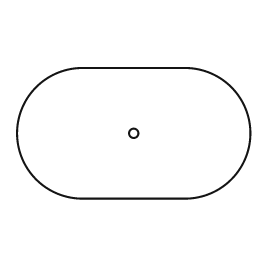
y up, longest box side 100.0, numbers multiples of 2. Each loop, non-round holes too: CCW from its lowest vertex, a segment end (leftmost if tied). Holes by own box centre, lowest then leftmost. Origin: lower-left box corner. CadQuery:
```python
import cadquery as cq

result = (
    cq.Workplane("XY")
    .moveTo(28.0, 0.0)
    .lineTo(72.0, 0.0)
    .threePointArc((100.0, 28.0), (72.0, 56.0))
    .lineTo(28.0, 56.0)
    .threePointArc((0.0, 28.0), (28.0, 0.0))
    .close()
    .moveTo(50.0, 28.0)
    .circle(2.0)
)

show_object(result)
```